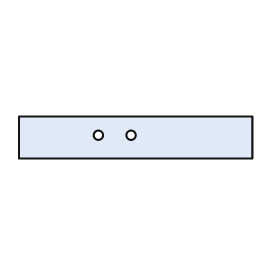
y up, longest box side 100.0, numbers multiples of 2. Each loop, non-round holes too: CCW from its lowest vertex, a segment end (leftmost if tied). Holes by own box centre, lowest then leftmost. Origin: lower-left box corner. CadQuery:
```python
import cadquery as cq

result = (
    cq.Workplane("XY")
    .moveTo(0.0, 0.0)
    .lineTo(100.0, 0.0)
    .lineTo(100.0, 18.0)
    .lineTo(0.0, 18.0)
    .close()
    .moveTo(34.0, 10.0)
    .circle(2.0)
    .moveTo(48.0, 10.0)
    .circle(2.0)
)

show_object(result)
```